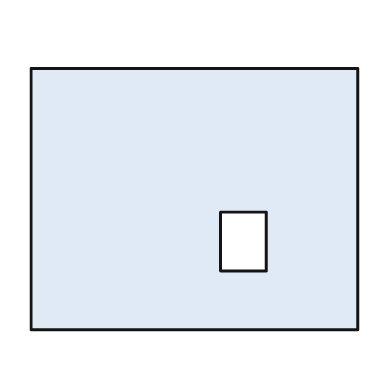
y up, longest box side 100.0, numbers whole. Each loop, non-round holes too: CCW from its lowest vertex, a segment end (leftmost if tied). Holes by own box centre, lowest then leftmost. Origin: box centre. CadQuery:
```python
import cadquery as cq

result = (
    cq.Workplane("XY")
    .moveTo(-50.0, -40.0)
    .lineTo(50.0, -40.0)
    .lineTo(50.0, 40.0)
    .lineTo(-50.0, 40.0)
    .close()
    .moveTo(8.0, -22.0)
    .lineTo(22.0, -22.0)
    .lineTo(22.0, -4.0)
    .lineTo(8.0, -4.0)
    .close()
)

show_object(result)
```